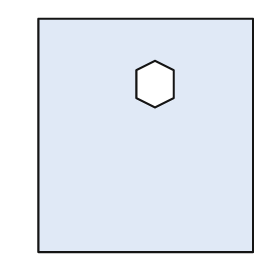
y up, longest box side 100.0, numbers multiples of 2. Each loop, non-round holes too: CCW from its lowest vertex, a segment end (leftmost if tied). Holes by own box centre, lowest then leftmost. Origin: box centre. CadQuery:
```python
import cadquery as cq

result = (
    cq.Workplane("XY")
    .moveTo(-46.0, -50.0)
    .lineTo(46.0, -50.0)
    .lineTo(46.0, 50.0)
    .lineTo(-46.0, 50.0)
    .close()
    .moveTo(4.0, 12.0)
    .lineTo(12.0, 16.0)
    .lineTo(12.0, 28.0)
    .lineTo(4.0, 32.0)
    .lineTo(-4.0, 28.0)
    .lineTo(-4.0, 16.0)
    .close()
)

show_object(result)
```